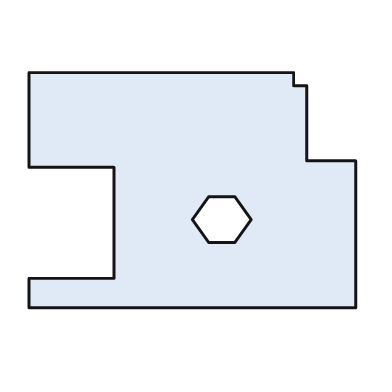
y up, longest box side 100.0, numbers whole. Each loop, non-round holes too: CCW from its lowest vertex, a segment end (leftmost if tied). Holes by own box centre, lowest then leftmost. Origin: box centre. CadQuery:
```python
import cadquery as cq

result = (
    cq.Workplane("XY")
    .moveTo(-50.0, -36.0)
    .lineTo(50.0, -36.0)
    .lineTo(50.0, 9.0)
    .lineTo(35.0, 9.0)
    .lineTo(35.0, 32.0)
    .lineTo(31.0, 32.0)
    .lineTo(31.0, 36.0)
    .lineTo(-50.0, 36.0)
    .lineTo(-50.0, 7.0)
    .lineTo(-24.0, 7.0)
    .lineTo(-24.0, -27.0)
    .lineTo(-50.0, -27.0)
    .close()
    .moveTo(5.0, -16.0)
    .lineTo(13.0, -16.0)
    .lineTo(18.0, -9.0)
    .lineTo(13.0, -2.0)
    .lineTo(5.0, -2.0)
    .lineTo(0.0, -9.0)
    .close()
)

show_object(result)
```